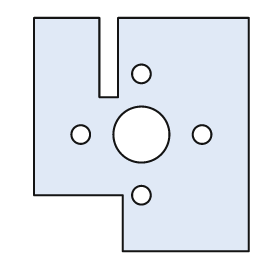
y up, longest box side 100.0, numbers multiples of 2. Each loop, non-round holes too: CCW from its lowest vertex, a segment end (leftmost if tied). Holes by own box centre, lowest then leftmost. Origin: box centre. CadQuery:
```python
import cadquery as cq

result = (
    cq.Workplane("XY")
    .moveTo(-8.0, -50.0)
    .lineTo(46.0, -50.0)
    .lineTo(46.0, 50.0)
    .lineTo(-10.0, 50.0)
    .lineTo(-10.0, 16.0)
    .lineTo(-18.0, 16.0)
    .lineTo(-18.0, 50.0)
    .lineTo(-46.0, 50.0)
    .lineTo(-46.0, -26.0)
    .lineTo(-8.0, -26.0)
    .close()
    .moveTo(0.0, -26.0)
    .circle(4.0)
    .moveTo(-26.0, 0.0)
    .circle(4.0)
    .moveTo(0.0, 0.0)
    .circle(12.0)
    .moveTo(26.0, 0.0)
    .circle(4.0)
    .moveTo(0.0, 26.0)
    .circle(4.0)
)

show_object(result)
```